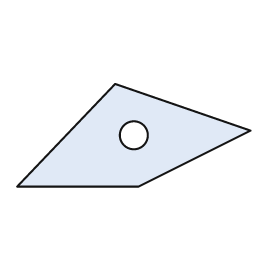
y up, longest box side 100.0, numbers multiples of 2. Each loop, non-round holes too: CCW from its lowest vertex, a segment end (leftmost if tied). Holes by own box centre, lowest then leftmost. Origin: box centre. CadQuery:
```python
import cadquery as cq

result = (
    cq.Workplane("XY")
    .moveTo(-50.0, -22.0)
    .lineTo(2.0, -22.0)
    .lineTo(50.0, 2.0)
    .lineTo(-8.0, 22.0)
    .close()
    .moveTo(0.0, 0.0)
    .circle(6.0)
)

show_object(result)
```